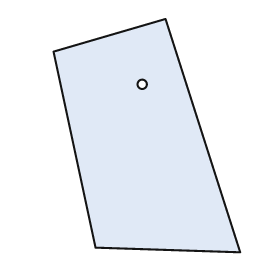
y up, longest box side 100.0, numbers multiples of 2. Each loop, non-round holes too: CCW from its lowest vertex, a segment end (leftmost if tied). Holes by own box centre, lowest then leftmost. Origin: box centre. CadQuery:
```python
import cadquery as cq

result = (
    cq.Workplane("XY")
    .moveTo(40.0, -50.0)
    .lineTo(8.0, 50.0)
    .lineTo(-40.0, 36.0)
    .lineTo(-22.0, -48.0)
    .close()
    .moveTo(-2.0, 22.0)
    .circle(2.0)
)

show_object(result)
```